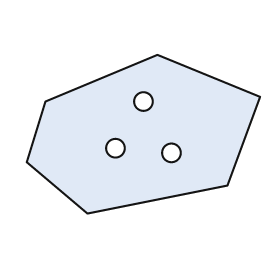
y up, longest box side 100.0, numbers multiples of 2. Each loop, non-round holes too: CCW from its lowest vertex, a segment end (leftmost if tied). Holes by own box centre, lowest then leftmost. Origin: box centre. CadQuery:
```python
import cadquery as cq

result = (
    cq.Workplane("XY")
    .moveTo(-24.0, -34.0)
    .lineTo(36.0, -22.0)
    .lineTo(50.0, 16.0)
    .lineTo(6.0, 34.0)
    .lineTo(-42.0, 14.0)
    .lineTo(-50.0, -12.0)
    .close()
    .moveTo(12.0, -8.0)
    .circle(4.0)
    .moveTo(-12.0, -6.0)
    .circle(4.0)
    .moveTo(0.0, 14.0)
    .circle(4.0)
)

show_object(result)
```